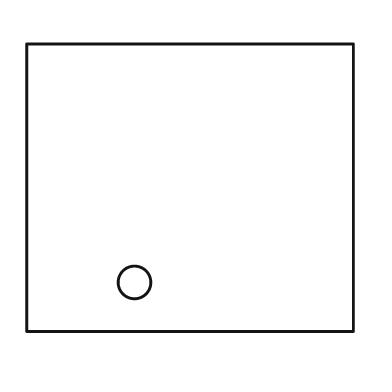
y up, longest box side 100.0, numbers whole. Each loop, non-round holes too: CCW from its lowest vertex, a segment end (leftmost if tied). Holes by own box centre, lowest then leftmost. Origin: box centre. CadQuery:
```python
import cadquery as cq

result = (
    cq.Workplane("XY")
    .moveTo(-50.0, -44.0)
    .lineTo(50.0, -44.0)
    .lineTo(50.0, 44.0)
    .lineTo(-50.0, 44.0)
    .close()
    .moveTo(-17.0, -29.0)
    .circle(5.0)
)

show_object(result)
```